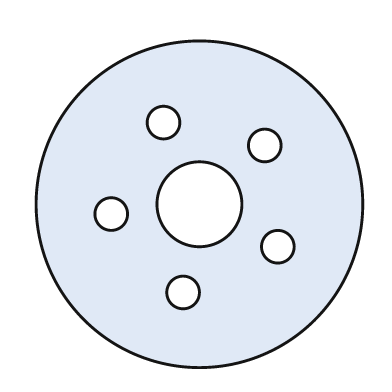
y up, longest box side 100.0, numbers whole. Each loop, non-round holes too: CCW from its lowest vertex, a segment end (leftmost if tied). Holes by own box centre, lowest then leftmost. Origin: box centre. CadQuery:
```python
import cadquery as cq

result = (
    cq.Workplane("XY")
    .moveTo(0.0, 0.0)
    .circle(50.0)
    .moveTo(-5.0, -27.0)
    .circle(5.0)
    .moveTo(24.0, -13.0)
    .circle(5.0)
    .moveTo(-27.0, -3.0)
    .circle(5.0)
    .moveTo(0.0, 0.0)
    .circle(13.0)
    .moveTo(20.0, 18.0)
    .circle(5.0)
    .moveTo(-11.0, 25.0)
    .circle(5.0)
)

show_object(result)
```